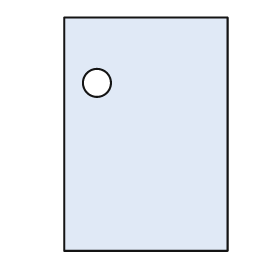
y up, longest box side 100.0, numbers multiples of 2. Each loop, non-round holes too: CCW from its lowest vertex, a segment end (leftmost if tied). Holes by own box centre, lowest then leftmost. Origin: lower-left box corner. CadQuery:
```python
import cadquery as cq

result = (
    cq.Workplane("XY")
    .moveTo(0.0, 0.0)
    .lineTo(70.0, 0.0)
    .lineTo(70.0, 100.0)
    .lineTo(0.0, 100.0)
    .close()
    .moveTo(14.0, 72.0)
    .circle(6.0)
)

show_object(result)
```